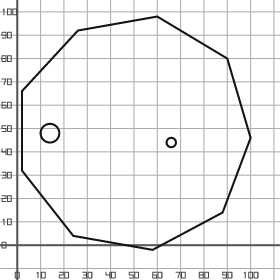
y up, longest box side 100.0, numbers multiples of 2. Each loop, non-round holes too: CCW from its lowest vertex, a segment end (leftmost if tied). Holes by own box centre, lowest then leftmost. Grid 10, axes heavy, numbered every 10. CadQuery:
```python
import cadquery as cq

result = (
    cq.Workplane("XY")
    .moveTo(58.0, -2.0)
    .lineTo(88.0, 14.0)
    .lineTo(100.0, 46.0)
    .lineTo(90.0, 80.0)
    .lineTo(60.0, 98.0)
    .lineTo(26.0, 92.0)
    .lineTo(2.0, 66.0)
    .lineTo(2.0, 32.0)
    .lineTo(24.0, 4.0)
    .close()
    .moveTo(66.0, 44.0)
    .circle(2.0)
    .moveTo(14.0, 48.0)
    .circle(4.0)
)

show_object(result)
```